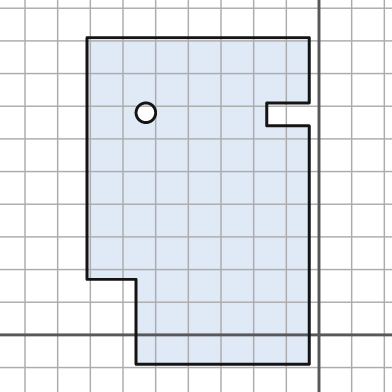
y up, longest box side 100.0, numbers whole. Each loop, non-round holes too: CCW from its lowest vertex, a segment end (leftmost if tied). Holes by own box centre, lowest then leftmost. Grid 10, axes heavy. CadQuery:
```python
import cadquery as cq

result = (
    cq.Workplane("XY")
    .moveTo(-56.0, -9.0)
    .lineTo(-3.0, -9.0)
    .lineTo(-3.0, 64.0)
    .lineTo(-16.0, 64.0)
    .lineTo(-16.0, 71.0)
    .lineTo(-3.0, 71.0)
    .lineTo(-3.0, 91.0)
    .lineTo(-71.0, 91.0)
    .lineTo(-71.0, 17.0)
    .lineTo(-56.0, 17.0)
    .close()
    .moveTo(-53.0, 68.0)
    .circle(3.0)
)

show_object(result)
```